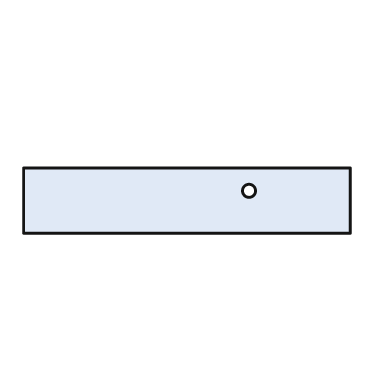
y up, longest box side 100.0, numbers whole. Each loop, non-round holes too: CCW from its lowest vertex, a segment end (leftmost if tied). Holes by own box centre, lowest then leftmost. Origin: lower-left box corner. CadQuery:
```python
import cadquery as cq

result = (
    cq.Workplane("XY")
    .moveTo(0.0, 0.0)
    .lineTo(100.0, 0.0)
    .lineTo(100.0, 20.0)
    .lineTo(0.0, 20.0)
    .close()
    .moveTo(69.0, 13.0)
    .circle(2.0)
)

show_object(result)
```